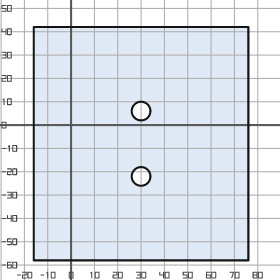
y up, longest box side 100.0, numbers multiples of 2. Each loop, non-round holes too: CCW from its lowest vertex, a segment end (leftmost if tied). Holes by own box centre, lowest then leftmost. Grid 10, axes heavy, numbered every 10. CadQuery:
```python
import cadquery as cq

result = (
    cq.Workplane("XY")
    .moveTo(-16.0, -58.0)
    .lineTo(76.0, -58.0)
    .lineTo(76.0, 42.0)
    .lineTo(-16.0, 42.0)
    .close()
    .moveTo(30.0, -22.0)
    .circle(4.0)
    .moveTo(30.0, 6.0)
    .circle(4.0)
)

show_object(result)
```